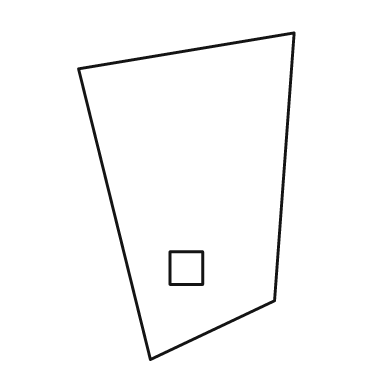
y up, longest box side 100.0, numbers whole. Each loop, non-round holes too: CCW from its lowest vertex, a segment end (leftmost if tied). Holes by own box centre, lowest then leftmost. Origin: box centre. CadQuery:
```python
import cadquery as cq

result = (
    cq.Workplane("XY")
    .moveTo(-11.0, -50.0)
    .lineTo(27.0, -32.0)
    .lineTo(33.0, 50.0)
    .lineTo(-33.0, 39.0)
    .close()
    .moveTo(-5.0, -27.0)
    .lineTo(5.0, -27.0)
    .lineTo(5.0, -17.0)
    .lineTo(-5.0, -17.0)
    .close()
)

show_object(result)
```